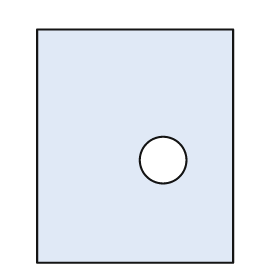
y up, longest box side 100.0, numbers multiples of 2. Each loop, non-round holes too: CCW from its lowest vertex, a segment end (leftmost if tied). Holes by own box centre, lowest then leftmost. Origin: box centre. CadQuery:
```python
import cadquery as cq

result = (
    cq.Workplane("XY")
    .moveTo(-42.0, -50.0)
    .lineTo(42.0, -50.0)
    .lineTo(42.0, 50.0)
    .lineTo(-42.0, 50.0)
    .close()
    .moveTo(12.0, -6.0)
    .circle(10.0)
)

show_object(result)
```